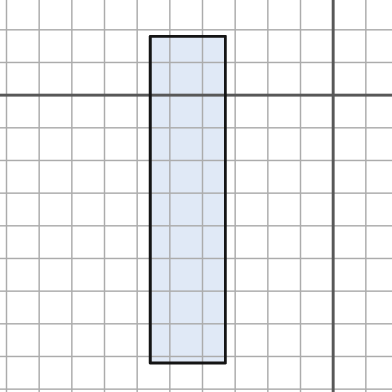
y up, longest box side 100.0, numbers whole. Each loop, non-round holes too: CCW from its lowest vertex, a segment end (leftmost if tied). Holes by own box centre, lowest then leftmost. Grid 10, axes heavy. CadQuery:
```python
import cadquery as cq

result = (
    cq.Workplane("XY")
    .moveTo(-56.0, -82.0)
    .lineTo(-33.0, -82.0)
    .lineTo(-33.0, 18.0)
    .lineTo(-56.0, 18.0)
    .close()
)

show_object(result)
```